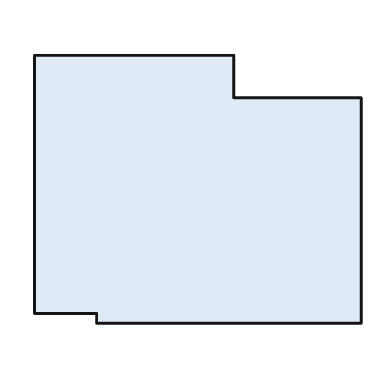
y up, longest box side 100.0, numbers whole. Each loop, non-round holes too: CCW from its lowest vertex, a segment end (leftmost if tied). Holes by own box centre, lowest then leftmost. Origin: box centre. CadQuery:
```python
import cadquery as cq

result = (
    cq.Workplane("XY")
    .moveTo(-31.0, -41.0)
    .lineTo(50.0, -41.0)
    .lineTo(50.0, 28.0)
    .lineTo(11.0, 28.0)
    .lineTo(11.0, 41.0)
    .lineTo(-50.0, 41.0)
    .lineTo(-50.0, -38.0)
    .lineTo(-31.0, -38.0)
    .close()
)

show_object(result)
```